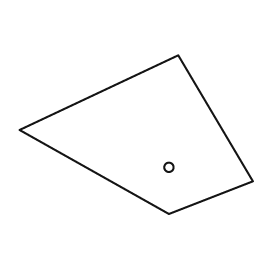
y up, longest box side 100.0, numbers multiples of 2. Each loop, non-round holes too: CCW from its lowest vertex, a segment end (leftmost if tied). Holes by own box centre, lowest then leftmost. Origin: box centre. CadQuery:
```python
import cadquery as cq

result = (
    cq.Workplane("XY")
    .moveTo(14.0, -34.0)
    .lineTo(50.0, -20.0)
    .lineTo(18.0, 34.0)
    .lineTo(-50.0, 2.0)
    .close()
    .moveTo(14.0, -14.0)
    .circle(2.0)
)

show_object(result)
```